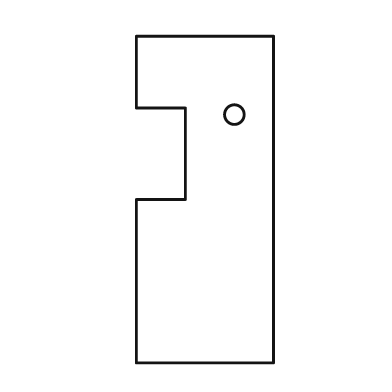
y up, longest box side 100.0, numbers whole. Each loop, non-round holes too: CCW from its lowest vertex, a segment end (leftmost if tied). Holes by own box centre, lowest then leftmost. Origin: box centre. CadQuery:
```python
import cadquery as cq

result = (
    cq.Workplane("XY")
    .moveTo(-21.0, -50.0)
    .lineTo(21.0, -50.0)
    .lineTo(21.0, 50.0)
    .lineTo(-21.0, 50.0)
    .lineTo(-21.0, 28.0)
    .lineTo(-6.0, 28.0)
    .lineTo(-6.0, 0.0)
    .lineTo(-21.0, 0.0)
    .close()
    .moveTo(9.0, 26.0)
    .circle(3.0)
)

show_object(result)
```